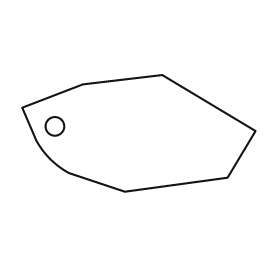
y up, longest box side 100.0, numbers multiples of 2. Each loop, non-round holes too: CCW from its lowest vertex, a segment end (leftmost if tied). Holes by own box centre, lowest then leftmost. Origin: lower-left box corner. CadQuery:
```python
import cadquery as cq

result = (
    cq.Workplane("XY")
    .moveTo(44.0, 0.0)
    .lineTo(88.0, 6.0)
    .lineTo(100.0, 26.0)
    .lineTo(60.0, 50.0)
    .lineTo(26.0, 46.0)
    .lineTo(0.0, 36.0)
    .lineTo(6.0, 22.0)
    .threePointArc((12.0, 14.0), (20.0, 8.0))
    .close()
    .moveTo(14.0, 28.0)
    .circle(4.0)
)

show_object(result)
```